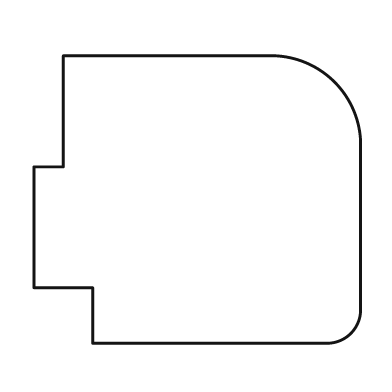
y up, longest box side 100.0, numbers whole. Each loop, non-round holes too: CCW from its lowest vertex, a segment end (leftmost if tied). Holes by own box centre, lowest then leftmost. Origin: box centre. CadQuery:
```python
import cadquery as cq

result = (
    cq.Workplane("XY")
    .moveTo(-32.0, -44.0)
    .lineTo(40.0, -44.0)
    .threePointArc((47.0, -41.0), (50.0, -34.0))
    .lineTo(50.0, 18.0)
    .threePointArc((42.0, 36.0), (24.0, 44.0))
    .lineTo(-41.0, 44.0)
    .lineTo(-41.0, 10.0)
    .lineTo(-50.0, 10.0)
    .lineTo(-50.0, -27.0)
    .lineTo(-32.0, -27.0)
    .close()
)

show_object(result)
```